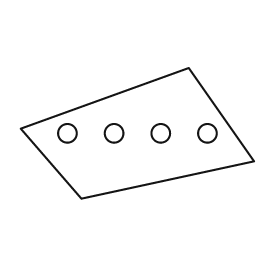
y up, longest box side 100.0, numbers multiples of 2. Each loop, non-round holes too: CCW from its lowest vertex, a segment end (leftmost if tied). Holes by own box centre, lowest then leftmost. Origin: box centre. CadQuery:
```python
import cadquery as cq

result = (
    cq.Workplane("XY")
    .moveTo(-24.0, -28.0)
    .lineTo(50.0, -12.0)
    .lineTo(22.0, 28.0)
    .lineTo(-50.0, 2.0)
    .close()
    .moveTo(-30.0, 0.0)
    .circle(4.0)
    .moveTo(-10.0, 0.0)
    .circle(4.0)
    .moveTo(10.0, 0.0)
    .circle(4.0)
    .moveTo(30.0, 0.0)
    .circle(4.0)
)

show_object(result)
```